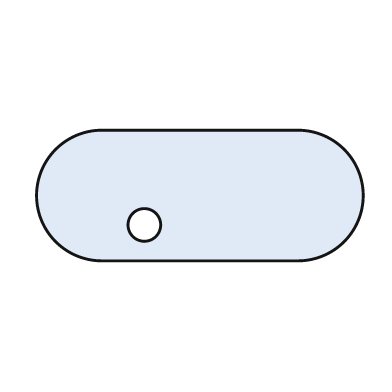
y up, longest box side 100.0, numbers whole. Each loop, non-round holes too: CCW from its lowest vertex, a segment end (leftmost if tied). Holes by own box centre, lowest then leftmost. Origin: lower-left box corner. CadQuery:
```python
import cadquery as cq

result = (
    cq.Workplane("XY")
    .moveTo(20.0, 0.0)
    .lineTo(80.0, 0.0)
    .threePointArc((100.0, 20.0), (80.0, 40.0))
    .lineTo(20.0, 40.0)
    .threePointArc((0.0, 20.0), (20.0, 0.0))
    .close()
    .moveTo(33.0, 11.0)
    .circle(5.0)
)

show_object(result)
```